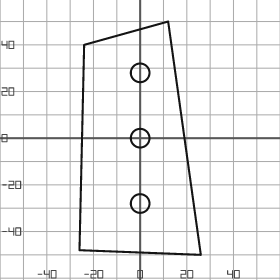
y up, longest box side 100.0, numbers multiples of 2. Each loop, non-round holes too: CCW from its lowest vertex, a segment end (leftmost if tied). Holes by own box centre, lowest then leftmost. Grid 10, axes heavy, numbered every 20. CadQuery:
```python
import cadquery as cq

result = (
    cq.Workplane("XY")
    .moveTo(26.0, -50.0)
    .lineTo(12.0, 50.0)
    .lineTo(-24.0, 40.0)
    .lineTo(-26.0, -48.0)
    .close()
    .moveTo(0.0, -28.0)
    .circle(4.0)
    .moveTo(0.0, 0.0)
    .circle(4.0)
    .moveTo(0.0, 28.0)
    .circle(4.0)
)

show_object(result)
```